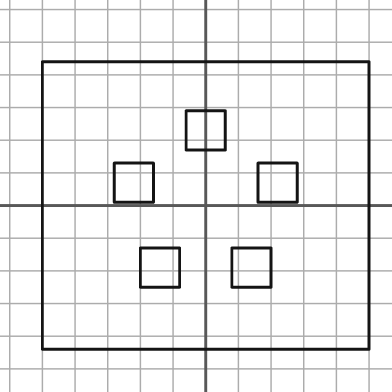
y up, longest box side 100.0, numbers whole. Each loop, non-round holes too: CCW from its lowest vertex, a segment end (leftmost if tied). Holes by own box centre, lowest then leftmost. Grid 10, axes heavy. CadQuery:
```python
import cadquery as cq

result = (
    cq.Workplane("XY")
    .moveTo(-50.0, -44.0)
    .lineTo(50.0, -44.0)
    .lineTo(50.0, 44.0)
    .lineTo(-50.0, 44.0)
    .close()
    .moveTo(-20.0, -25.0)
    .lineTo(-8.0, -25.0)
    .lineTo(-8.0, -13.0)
    .lineTo(-20.0, -13.0)
    .close()
    .moveTo(8.0, -25.0)
    .lineTo(20.0, -25.0)
    .lineTo(20.0, -13.0)
    .lineTo(8.0, -13.0)
    .close()
    .moveTo(-28.0, 1.0)
    .lineTo(-16.0, 1.0)
    .lineTo(-16.0, 13.0)
    .lineTo(-28.0, 13.0)
    .close()
    .moveTo(16.0, 1.0)
    .lineTo(28.0, 1.0)
    .lineTo(28.0, 13.0)
    .lineTo(16.0, 13.0)
    .close()
    .moveTo(-6.0, 17.0)
    .lineTo(6.0, 17.0)
    .lineTo(6.0, 29.0)
    .lineTo(-6.0, 29.0)
    .close()
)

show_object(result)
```